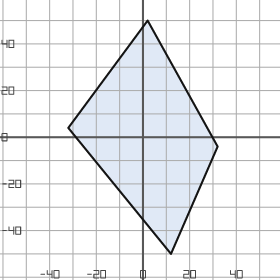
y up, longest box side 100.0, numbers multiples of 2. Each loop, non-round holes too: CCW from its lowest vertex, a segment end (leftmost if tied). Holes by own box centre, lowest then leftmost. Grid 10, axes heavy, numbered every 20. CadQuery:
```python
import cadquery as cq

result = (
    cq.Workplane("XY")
    .moveTo(12.0, -50.0)
    .lineTo(32.0, -4.0)
    .lineTo(2.0, 50.0)
    .lineTo(-32.0, 4.0)
    .close()
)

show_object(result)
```